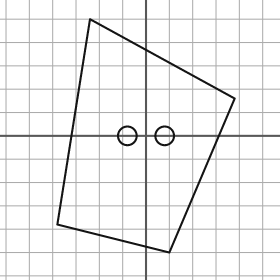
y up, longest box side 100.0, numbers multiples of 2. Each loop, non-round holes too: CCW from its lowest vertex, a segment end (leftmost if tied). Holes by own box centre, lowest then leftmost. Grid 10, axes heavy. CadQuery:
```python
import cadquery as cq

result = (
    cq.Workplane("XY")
    .moveTo(10.0, -50.0)
    .lineTo(38.0, 16.0)
    .lineTo(-24.0, 50.0)
    .lineTo(-38.0, -38.0)
    .close()
    .moveTo(-8.0, 0.0)
    .circle(4.0)
    .moveTo(8.0, 0.0)
    .circle(4.0)
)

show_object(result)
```